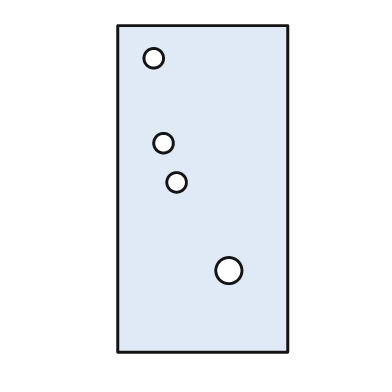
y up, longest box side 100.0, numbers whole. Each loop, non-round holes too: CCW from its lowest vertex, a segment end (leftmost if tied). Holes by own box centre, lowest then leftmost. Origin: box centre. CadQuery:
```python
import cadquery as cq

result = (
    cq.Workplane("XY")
    .moveTo(-26.0, -50.0)
    .lineTo(26.0, -50.0)
    .lineTo(26.0, 50.0)
    .lineTo(-26.0, 50.0)
    .close()
    .moveTo(8.0, -25.0)
    .circle(4.0)
    .moveTo(-8.0, 2.0)
    .circle(3.0)
    .moveTo(-12.0, 14.0)
    .circle(3.0)
    .moveTo(-15.0, 40.0)
    .circle(3.0)
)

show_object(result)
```